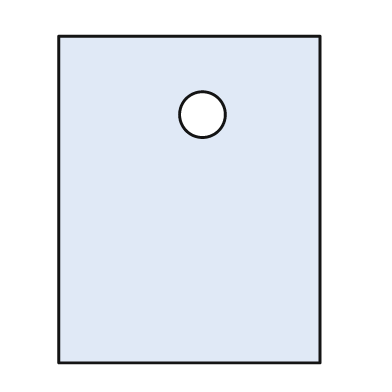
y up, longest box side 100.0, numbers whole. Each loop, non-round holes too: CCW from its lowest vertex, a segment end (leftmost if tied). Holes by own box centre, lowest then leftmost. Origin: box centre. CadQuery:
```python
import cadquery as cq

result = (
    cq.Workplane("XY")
    .moveTo(-40.0, -50.0)
    .lineTo(40.0, -50.0)
    .lineTo(40.0, 50.0)
    .lineTo(-40.0, 50.0)
    .close()
    .moveTo(4.0, 26.0)
    .circle(7.0)
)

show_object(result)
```